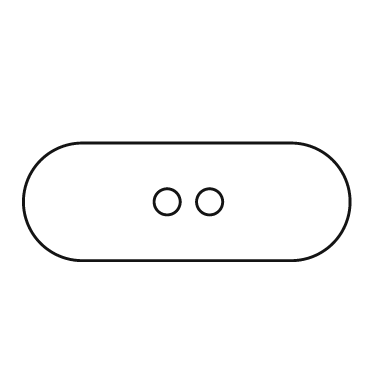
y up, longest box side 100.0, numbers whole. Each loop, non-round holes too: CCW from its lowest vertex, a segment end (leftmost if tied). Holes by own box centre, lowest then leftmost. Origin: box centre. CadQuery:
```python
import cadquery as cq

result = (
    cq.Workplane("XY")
    .moveTo(-32.0, -18.0)
    .lineTo(32.0, -18.0)
    .threePointArc((50.0, 0.0), (32.0, 18.0))
    .lineTo(-32.0, 18.0)
    .threePointArc((-50.0, 0.0), (-32.0, -18.0))
    .close()
    .moveTo(-6.0, 0.0)
    .circle(4.0)
    .moveTo(7.0, 0.0)
    .circle(4.0)
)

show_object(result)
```